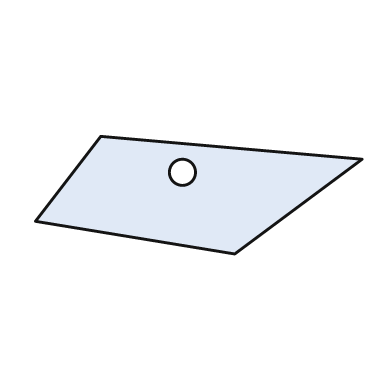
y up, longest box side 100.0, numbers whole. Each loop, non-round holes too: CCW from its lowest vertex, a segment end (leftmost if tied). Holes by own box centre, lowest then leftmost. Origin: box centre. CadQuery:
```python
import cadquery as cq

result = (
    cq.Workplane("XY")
    .moveTo(11.0, -18.0)
    .lineTo(50.0, 11.0)
    .lineTo(-30.0, 18.0)
    .lineTo(-50.0, -8.0)
    .close()
    .moveTo(-5.0, 7.0)
    .circle(4.0)
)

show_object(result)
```